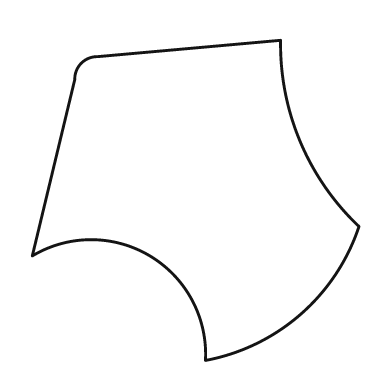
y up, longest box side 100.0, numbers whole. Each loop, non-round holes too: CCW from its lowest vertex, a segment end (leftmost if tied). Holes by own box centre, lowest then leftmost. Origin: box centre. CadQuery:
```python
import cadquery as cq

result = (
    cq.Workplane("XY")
    .moveTo(3.0, -49.0)
    .threePointArc((32.0, -35.0), (50.0, -8.0))
    .threePointArc((32.0, 18.0), (26.0, 49.0))
    .lineTo(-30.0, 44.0)
    .threePointArc((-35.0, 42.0), (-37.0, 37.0))
    .lineTo(-50.0, -17.0)
    .threePointArc((-14.0, -17.0), (3.0, -49.0))
    .close()
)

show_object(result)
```